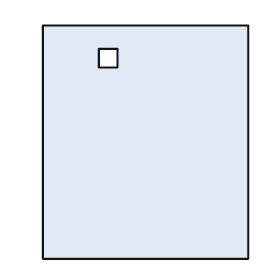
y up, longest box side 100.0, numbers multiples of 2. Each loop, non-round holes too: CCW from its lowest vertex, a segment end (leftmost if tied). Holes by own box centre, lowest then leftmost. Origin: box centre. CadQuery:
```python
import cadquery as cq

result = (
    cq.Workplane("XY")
    .moveTo(-44.0, -50.0)
    .lineTo(44.0, -50.0)
    .lineTo(44.0, 50.0)
    .lineTo(-44.0, 50.0)
    .close()
    .moveTo(-20.0, 32.0)
    .lineTo(-12.0, 32.0)
    .lineTo(-12.0, 40.0)
    .lineTo(-20.0, 40.0)
    .close()
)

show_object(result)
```